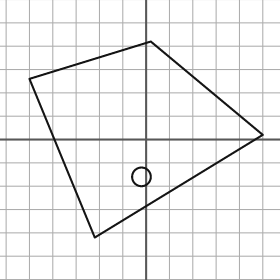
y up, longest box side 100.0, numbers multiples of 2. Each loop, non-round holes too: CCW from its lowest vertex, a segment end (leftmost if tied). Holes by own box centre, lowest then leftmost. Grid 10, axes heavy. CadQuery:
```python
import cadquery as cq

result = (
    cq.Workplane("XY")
    .moveTo(-22.0, -42.0)
    .lineTo(50.0, 2.0)
    .lineTo(2.0, 42.0)
    .lineTo(-50.0, 26.0)
    .close()
    .moveTo(-2.0, -16.0)
    .circle(4.0)
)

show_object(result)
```